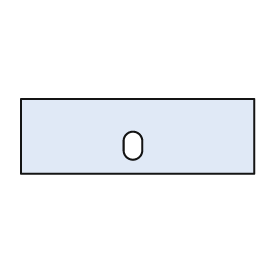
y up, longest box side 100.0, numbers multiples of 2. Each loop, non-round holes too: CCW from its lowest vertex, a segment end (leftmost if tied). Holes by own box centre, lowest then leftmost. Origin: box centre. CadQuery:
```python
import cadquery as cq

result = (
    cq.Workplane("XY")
    .moveTo(-50.0, -16.0)
    .lineTo(50.0, -16.0)
    .lineTo(50.0, 16.0)
    .lineTo(-50.0, 16.0)
    .close()
    .moveTo(-6.0, -6.0)
    .threePointArc((-2.0, -10.0), (2.0, -6.0))
    .lineTo(2.0, -2.0)
    .threePointArc((-2.0, 2.0), (-6.0, -2.0))
    .close()
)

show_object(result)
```